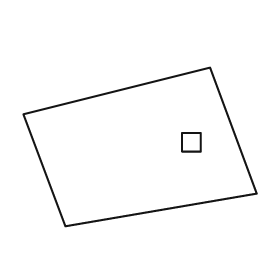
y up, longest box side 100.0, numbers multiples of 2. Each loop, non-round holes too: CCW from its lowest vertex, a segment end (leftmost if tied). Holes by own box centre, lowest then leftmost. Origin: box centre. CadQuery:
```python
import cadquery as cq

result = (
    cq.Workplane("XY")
    .moveTo(-32.0, -34.0)
    .lineTo(50.0, -20.0)
    .lineTo(30.0, 34.0)
    .lineTo(-50.0, 14.0)
    .close()
    .moveTo(18.0, -2.0)
    .lineTo(26.0, -2.0)
    .lineTo(26.0, 6.0)
    .lineTo(18.0, 6.0)
    .close()
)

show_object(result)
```